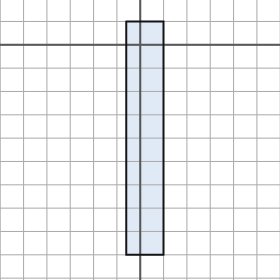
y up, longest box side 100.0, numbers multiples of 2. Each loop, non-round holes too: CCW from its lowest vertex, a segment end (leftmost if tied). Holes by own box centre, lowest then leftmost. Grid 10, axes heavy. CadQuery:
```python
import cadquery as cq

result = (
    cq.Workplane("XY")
    .moveTo(-6.0, -90.0)
    .lineTo(10.0, -90.0)
    .lineTo(10.0, 10.0)
    .lineTo(-6.0, 10.0)
    .close()
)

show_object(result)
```